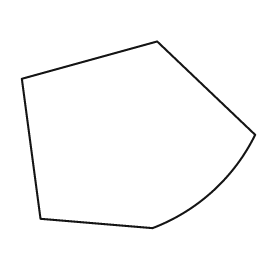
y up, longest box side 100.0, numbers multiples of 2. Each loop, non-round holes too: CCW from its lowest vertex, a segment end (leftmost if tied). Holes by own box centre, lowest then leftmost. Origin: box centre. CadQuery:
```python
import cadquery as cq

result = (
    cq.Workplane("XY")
    .moveTo(6.0, -40.0)
    .threePointArc((32.0, -24.0), (50.0, 0.0))
    .lineTo(8.0, 40.0)
    .lineTo(-50.0, 24.0)
    .lineTo(-42.0, -36.0)
    .close()
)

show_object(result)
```